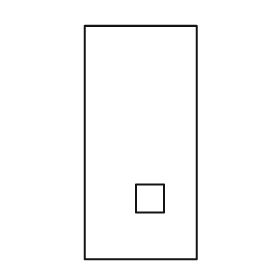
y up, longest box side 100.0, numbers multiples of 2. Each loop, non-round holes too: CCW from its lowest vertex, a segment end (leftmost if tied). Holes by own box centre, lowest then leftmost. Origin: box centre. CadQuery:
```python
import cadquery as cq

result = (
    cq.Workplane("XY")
    .moveTo(-24.0, -50.0)
    .lineTo(24.0, -50.0)
    .lineTo(24.0, 50.0)
    .lineTo(-24.0, 50.0)
    .close()
    .moveTo(-2.0, -30.0)
    .lineTo(10.0, -30.0)
    .lineTo(10.0, -18.0)
    .lineTo(-2.0, -18.0)
    .close()
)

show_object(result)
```